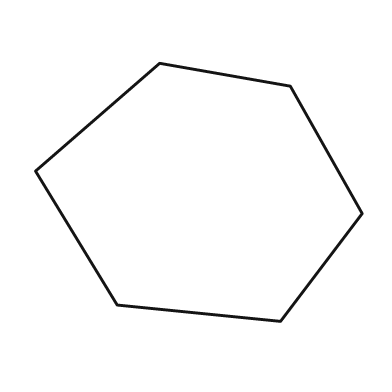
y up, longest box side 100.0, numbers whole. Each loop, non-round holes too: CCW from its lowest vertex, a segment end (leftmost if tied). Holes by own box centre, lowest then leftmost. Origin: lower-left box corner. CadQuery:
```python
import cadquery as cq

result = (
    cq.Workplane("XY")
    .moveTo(75.0, 0.0)
    .lineTo(100.0, 33.0)
    .lineTo(78.0, 72.0)
    .lineTo(38.0, 79.0)
    .lineTo(0.0, 46.0)
    .lineTo(25.0, 5.0)
    .close()
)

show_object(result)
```